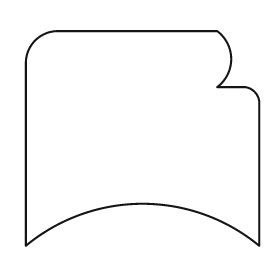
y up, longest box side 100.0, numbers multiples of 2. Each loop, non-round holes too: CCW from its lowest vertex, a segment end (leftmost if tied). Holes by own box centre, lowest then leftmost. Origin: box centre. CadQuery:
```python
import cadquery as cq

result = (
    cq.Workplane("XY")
    .moveTo(-50.0, -46.0)
    .threePointArc((0.0, -28.0), (50.0, -46.0))
    .lineTo(50.0, 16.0)
    .threePointArc((48.0, 20.0), (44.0, 22.0))
    .lineTo(32.0, 22.0)
    .threePointArc((38.0, 34.0), (32.0, 46.0))
    .lineTo(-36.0, 46.0)
    .threePointArc((-46.0, 42.0), (-50.0, 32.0))
    .close()
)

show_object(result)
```